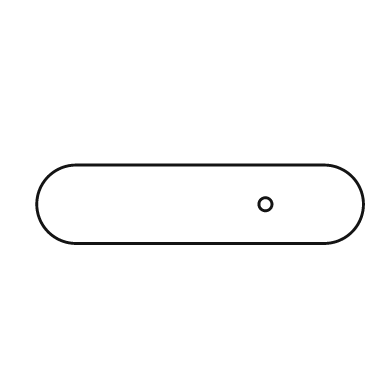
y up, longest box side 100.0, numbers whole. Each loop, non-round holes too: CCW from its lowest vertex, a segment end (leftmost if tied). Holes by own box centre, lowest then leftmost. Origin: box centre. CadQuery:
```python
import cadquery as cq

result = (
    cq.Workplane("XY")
    .moveTo(-38.0, -12.0)
    .lineTo(38.0, -12.0)
    .threePointArc((50.0, 0.0), (38.0, 12.0))
    .lineTo(-38.0, 12.0)
    .threePointArc((-50.0, 0.0), (-38.0, -12.0))
    .close()
    .moveTo(20.0, 0.0)
    .circle(2.0)
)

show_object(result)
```